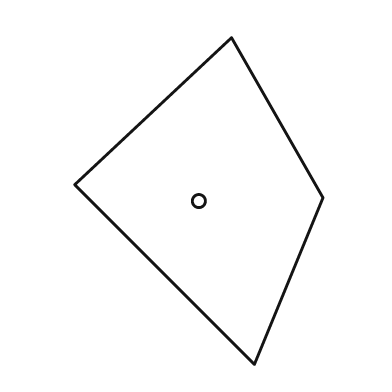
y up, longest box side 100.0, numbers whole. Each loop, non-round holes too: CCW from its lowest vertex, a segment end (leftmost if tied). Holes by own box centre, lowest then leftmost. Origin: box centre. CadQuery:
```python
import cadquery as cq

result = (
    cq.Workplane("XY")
    .moveTo(17.0, -50.0)
    .lineTo(38.0, 1.0)
    .lineTo(10.0, 50.0)
    .lineTo(-38.0, 5.0)
    .close()
    .moveTo(0.0, 0.0)
    .circle(2.0)
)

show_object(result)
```